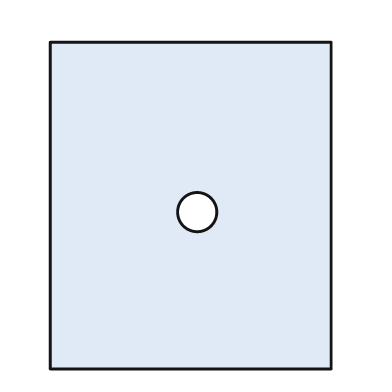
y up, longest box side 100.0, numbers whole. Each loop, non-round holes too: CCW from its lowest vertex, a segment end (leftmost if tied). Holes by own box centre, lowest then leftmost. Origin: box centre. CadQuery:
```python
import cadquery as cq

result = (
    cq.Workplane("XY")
    .moveTo(-43.0, -50.0)
    .lineTo(43.0, -50.0)
    .lineTo(43.0, 50.0)
    .lineTo(-43.0, 50.0)
    .close()
    .moveTo(2.0, -2.0)
    .circle(6.0)
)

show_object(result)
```